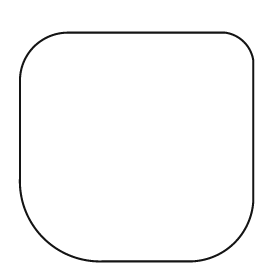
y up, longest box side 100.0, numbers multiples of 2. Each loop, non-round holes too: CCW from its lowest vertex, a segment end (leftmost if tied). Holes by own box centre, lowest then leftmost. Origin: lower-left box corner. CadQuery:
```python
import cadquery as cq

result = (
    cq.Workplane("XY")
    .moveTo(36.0, 0.0)
    .lineTo(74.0, 0.0)
    .threePointArc((92.0, 8.0), (100.0, 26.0))
    .lineTo(100.0, 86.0)
    .threePointArc((96.0, 94.0), (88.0, 98.0))
    .lineTo(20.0, 98.0)
    .threePointArc((6.0, 92.0), (0.0, 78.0))
    .lineTo(0.0, 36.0)
    .threePointArc((10.0, 10.0), (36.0, 0.0))
    .close()
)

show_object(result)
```